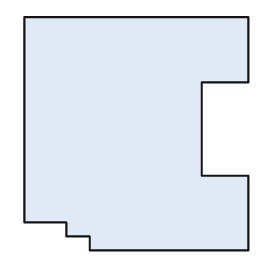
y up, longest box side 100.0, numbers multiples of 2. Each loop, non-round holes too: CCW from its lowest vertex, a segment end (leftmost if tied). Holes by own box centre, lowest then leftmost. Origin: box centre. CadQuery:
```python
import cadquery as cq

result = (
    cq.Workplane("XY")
    .moveTo(-20.0, -50.0)
    .lineTo(48.0, -50.0)
    .lineTo(48.0, -18.0)
    .lineTo(28.0, -18.0)
    .lineTo(28.0, 22.0)
    .lineTo(48.0, 22.0)
    .lineTo(48.0, 50.0)
    .lineTo(-48.0, 50.0)
    .lineTo(-48.0, -38.0)
    .lineTo(-30.0, -38.0)
    .lineTo(-30.0, -44.0)
    .lineTo(-20.0, -44.0)
    .close()
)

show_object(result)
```